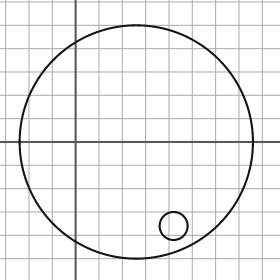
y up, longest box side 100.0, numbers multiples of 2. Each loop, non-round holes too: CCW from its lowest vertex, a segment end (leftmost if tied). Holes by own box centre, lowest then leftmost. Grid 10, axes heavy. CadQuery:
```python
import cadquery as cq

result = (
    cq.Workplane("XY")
    .moveTo(26.0, 0.0)
    .circle(50.0)
    .moveTo(42.0, -36.0)
    .circle(6.0)
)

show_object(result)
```